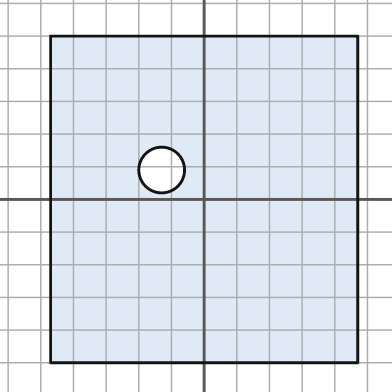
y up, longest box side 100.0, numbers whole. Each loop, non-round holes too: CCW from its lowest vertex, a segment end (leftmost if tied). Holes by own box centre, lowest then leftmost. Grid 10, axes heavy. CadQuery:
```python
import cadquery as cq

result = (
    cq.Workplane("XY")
    .moveTo(-47.0, -50.0)
    .lineTo(47.0, -50.0)
    .lineTo(47.0, 50.0)
    .lineTo(-47.0, 50.0)
    .close()
    .moveTo(-13.0, 9.0)
    .circle(7.0)
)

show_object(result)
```